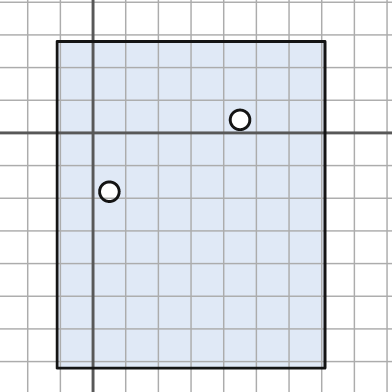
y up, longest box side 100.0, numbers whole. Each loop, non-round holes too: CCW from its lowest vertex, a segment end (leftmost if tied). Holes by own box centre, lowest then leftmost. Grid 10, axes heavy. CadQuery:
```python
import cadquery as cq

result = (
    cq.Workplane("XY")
    .moveTo(-11.0, -72.0)
    .lineTo(71.0, -72.0)
    .lineTo(71.0, 28.0)
    .lineTo(-11.0, 28.0)
    .close()
    .moveTo(5.0, -18.0)
    .circle(3.0)
    .moveTo(45.0, 4.0)
    .circle(3.0)
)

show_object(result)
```